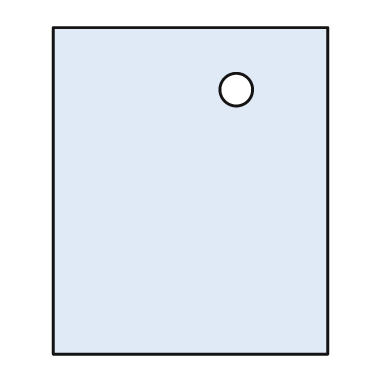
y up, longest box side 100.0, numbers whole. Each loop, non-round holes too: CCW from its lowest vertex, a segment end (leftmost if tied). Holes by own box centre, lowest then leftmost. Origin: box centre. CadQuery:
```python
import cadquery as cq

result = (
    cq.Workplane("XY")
    .moveTo(-42.0, -50.0)
    .lineTo(42.0, -50.0)
    .lineTo(42.0, 50.0)
    .lineTo(-42.0, 50.0)
    .close()
    .moveTo(14.0, 31.0)
    .circle(5.0)
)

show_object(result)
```